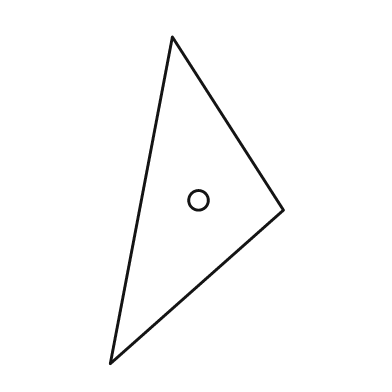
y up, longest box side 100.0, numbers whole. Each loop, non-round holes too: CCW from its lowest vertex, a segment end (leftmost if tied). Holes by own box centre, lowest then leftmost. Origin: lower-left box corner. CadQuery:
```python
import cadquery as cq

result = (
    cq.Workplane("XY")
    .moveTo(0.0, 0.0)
    .lineTo(53.0, 47.0)
    .lineTo(19.0, 100.0)
    .close()
    .moveTo(27.0, 50.0)
    .circle(3.0)
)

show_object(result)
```